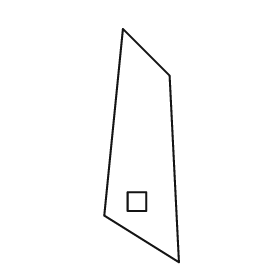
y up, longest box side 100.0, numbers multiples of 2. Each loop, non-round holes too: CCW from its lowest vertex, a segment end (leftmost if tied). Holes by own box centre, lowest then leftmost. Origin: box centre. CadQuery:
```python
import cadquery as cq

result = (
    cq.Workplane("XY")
    .moveTo(16.0, -50.0)
    .lineTo(12.0, 30.0)
    .lineTo(-8.0, 50.0)
    .lineTo(-16.0, -30.0)
    .close()
    .moveTo(-6.0, -28.0)
    .lineTo(2.0, -28.0)
    .lineTo(2.0, -20.0)
    .lineTo(-6.0, -20.0)
    .close()
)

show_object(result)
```